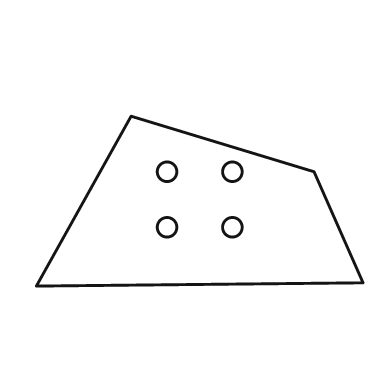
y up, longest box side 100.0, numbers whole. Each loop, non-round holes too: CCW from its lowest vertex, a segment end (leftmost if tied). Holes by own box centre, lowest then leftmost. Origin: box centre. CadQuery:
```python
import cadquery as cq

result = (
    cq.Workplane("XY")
    .moveTo(-50.0, -26.0)
    .lineTo(50.0, -25.0)
    .lineTo(35.0, 9.0)
    .lineTo(-21.0, 26.0)
    .close()
    .moveTo(-10.0, -8.0)
    .circle(3.0)
    .moveTo(10.0, -8.0)
    .circle(3.0)
    .moveTo(-10.0, 9.0)
    .circle(3.0)
    .moveTo(10.0, 9.0)
    .circle(3.0)
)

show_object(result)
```